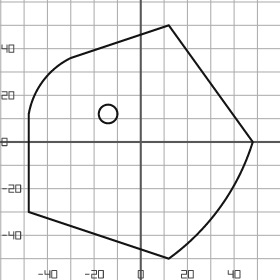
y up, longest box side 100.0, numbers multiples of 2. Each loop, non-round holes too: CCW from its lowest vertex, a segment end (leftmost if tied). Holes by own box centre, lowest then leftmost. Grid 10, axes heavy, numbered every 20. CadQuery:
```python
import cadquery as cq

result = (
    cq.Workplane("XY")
    .moveTo(12.0, -50.0)
    .threePointArc((34.0, -28.0), (48.0, 0.0))
    .lineTo(12.0, 50.0)
    .lineTo(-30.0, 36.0)
    .threePointArc((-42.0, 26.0), (-48.0, 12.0))
    .lineTo(-48.0, -30.0)
    .close()
    .moveTo(-14.0, 12.0)
    .circle(4.0)
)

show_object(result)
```